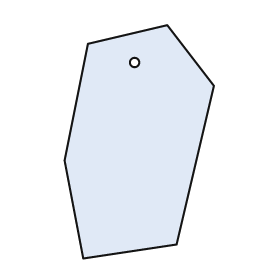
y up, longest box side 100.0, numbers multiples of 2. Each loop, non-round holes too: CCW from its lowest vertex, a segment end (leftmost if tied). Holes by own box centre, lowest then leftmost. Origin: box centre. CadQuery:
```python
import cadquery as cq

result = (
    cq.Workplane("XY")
    .moveTo(-24.0, -50.0)
    .lineTo(16.0, -44.0)
    .lineTo(32.0, 24.0)
    .lineTo(12.0, 50.0)
    .lineTo(-22.0, 42.0)
    .lineTo(-32.0, -8.0)
    .close()
    .moveTo(-2.0, 34.0)
    .circle(2.0)
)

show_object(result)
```